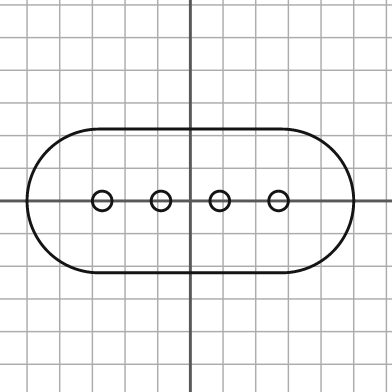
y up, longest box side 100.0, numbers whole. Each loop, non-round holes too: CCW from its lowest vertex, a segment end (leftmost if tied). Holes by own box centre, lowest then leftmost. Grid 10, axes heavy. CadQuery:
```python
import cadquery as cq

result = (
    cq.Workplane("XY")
    .moveTo(-28.0, -22.0)
    .lineTo(28.0, -22.0)
    .threePointArc((50.0, 0.0), (28.0, 22.0))
    .lineTo(-28.0, 22.0)
    .threePointArc((-50.0, 0.0), (-28.0, -22.0))
    .close()
    .moveTo(-27.0, 0.0)
    .circle(3.0)
    .moveTo(-9.0, 0.0)
    .circle(3.0)
    .moveTo(9.0, 0.0)
    .circle(3.0)
    .moveTo(27.0, 0.0)
    .circle(3.0)
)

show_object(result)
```